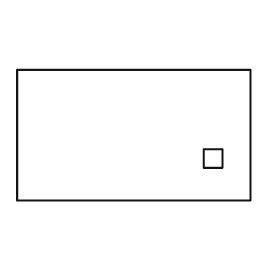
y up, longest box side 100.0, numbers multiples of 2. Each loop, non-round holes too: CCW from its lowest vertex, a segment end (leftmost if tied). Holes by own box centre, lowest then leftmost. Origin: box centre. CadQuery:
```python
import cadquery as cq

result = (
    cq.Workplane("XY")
    .moveTo(-50.0, -28.0)
    .lineTo(50.0, -28.0)
    .lineTo(50.0, 28.0)
    .lineTo(-50.0, 28.0)
    .close()
    .moveTo(30.0, -14.0)
    .lineTo(38.0, -14.0)
    .lineTo(38.0, -6.0)
    .lineTo(30.0, -6.0)
    .close()
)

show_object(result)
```